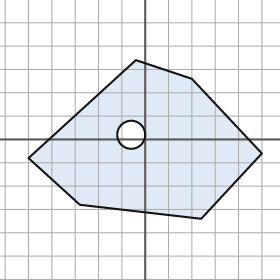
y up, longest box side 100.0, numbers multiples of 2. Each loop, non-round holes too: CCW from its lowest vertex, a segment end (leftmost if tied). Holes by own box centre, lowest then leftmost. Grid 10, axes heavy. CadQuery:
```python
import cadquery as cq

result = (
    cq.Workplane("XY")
    .moveTo(24.0, -34.0)
    .lineTo(50.0, -6.0)
    .lineTo(20.0, 26.0)
    .lineTo(-4.0, 34.0)
    .lineTo(-50.0, -8.0)
    .lineTo(-28.0, -28.0)
    .close()
    .moveTo(-6.0, 2.0)
    .circle(6.0)
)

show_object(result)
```